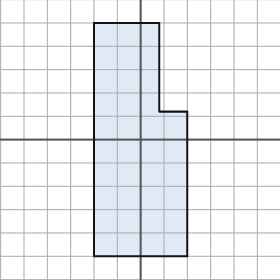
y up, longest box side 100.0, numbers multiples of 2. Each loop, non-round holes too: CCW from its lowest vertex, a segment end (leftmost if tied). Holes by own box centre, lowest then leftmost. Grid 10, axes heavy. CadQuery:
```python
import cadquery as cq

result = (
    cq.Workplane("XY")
    .moveTo(-20.0, -50.0)
    .lineTo(20.0, -50.0)
    .lineTo(20.0, 12.0)
    .lineTo(8.0, 12.0)
    .lineTo(8.0, 50.0)
    .lineTo(-20.0, 50.0)
    .close()
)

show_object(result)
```